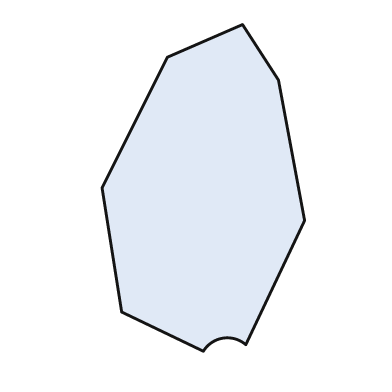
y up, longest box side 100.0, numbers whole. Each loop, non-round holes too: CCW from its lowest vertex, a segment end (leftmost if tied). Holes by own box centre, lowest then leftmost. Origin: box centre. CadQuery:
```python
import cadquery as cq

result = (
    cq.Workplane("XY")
    .moveTo(0.0, -50.0)
    .threePointArc((6.0, -46.0), (13.0, -48.0))
    .lineTo(31.0, -10.0)
    .lineTo(23.0, 33.0)
    .lineTo(12.0, 50.0)
    .lineTo(-11.0, 40.0)
    .lineTo(-31.0, 0.0)
    .lineTo(-25.0, -38.0)
    .close()
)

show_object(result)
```